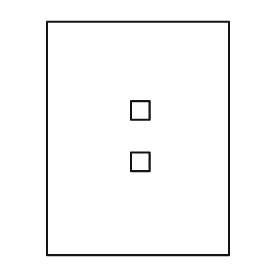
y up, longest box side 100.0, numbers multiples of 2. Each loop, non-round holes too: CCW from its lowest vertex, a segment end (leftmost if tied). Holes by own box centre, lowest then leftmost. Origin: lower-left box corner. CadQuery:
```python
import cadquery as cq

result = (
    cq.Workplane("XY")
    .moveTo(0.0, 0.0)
    .lineTo(78.0, 0.0)
    .lineTo(78.0, 100.0)
    .lineTo(0.0, 100.0)
    .close()
    .moveTo(36.0, 36.0)
    .lineTo(44.0, 36.0)
    .lineTo(44.0, 44.0)
    .lineTo(36.0, 44.0)
    .close()
    .moveTo(36.0, 58.0)
    .lineTo(44.0, 58.0)
    .lineTo(44.0, 66.0)
    .lineTo(36.0, 66.0)
    .close()
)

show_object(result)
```